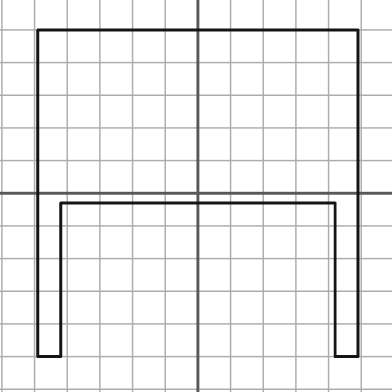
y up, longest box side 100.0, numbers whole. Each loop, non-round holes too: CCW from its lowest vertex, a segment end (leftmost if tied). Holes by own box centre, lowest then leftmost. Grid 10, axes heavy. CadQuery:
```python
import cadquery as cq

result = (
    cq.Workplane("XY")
    .moveTo(-49.0, -50.0)
    .lineTo(-42.0, -50.0)
    .lineTo(-42.0, -3.0)
    .lineTo(42.0, -3.0)
    .lineTo(42.0, -50.0)
    .lineTo(49.0, -50.0)
    .lineTo(49.0, 50.0)
    .lineTo(-49.0, 50.0)
    .close()
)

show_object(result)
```